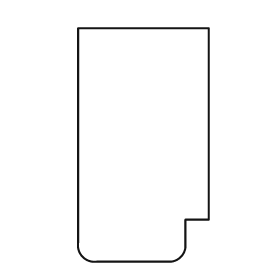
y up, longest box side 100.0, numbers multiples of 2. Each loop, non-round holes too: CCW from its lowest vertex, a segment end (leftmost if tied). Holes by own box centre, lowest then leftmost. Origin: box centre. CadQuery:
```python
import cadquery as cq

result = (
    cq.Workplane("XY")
    .moveTo(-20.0, -50.0)
    .lineTo(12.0, -50.0)
    .threePointArc((16.0, -48.0), (18.0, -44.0))
    .lineTo(18.0, -32.0)
    .lineTo(28.0, -32.0)
    .lineTo(28.0, 50.0)
    .lineTo(-28.0, 50.0)
    .lineTo(-28.0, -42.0)
    .threePointArc((-26.0, -48.0), (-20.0, -50.0))
    .close()
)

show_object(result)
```